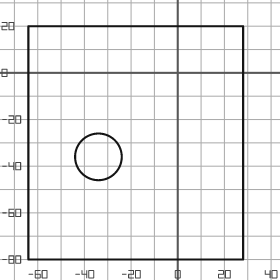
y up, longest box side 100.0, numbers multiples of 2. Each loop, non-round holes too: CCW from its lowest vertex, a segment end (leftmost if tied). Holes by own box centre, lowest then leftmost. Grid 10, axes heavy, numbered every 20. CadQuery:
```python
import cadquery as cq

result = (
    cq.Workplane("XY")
    .moveTo(-64.0, -80.0)
    .lineTo(28.0, -80.0)
    .lineTo(28.0, 20.0)
    .lineTo(-64.0, 20.0)
    .close()
    .moveTo(-34.0, -36.0)
    .circle(10.0)
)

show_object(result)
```